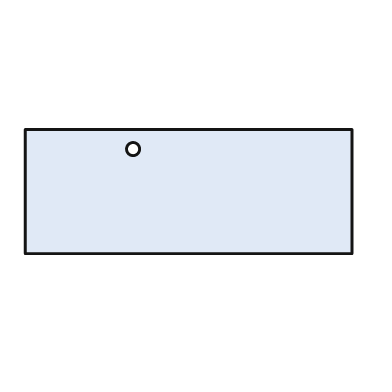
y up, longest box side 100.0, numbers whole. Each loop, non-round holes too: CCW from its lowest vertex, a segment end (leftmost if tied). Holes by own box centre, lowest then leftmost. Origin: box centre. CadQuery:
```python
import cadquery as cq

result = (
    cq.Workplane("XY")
    .moveTo(-50.0, -19.0)
    .lineTo(50.0, -19.0)
    .lineTo(50.0, 19.0)
    .lineTo(-50.0, 19.0)
    .close()
    .moveTo(-17.0, 13.0)
    .circle(2.0)
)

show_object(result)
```